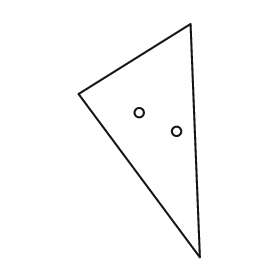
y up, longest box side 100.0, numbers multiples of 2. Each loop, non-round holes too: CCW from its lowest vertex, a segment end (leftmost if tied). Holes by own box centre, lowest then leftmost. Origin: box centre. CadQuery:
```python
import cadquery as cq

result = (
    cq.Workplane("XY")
    .moveTo(26.0, -50.0)
    .lineTo(22.0, 50.0)
    .lineTo(-26.0, 20.0)
    .close()
    .moveTo(16.0, 4.0)
    .circle(2.0)
    .moveTo(0.0, 12.0)
    .circle(2.0)
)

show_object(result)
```